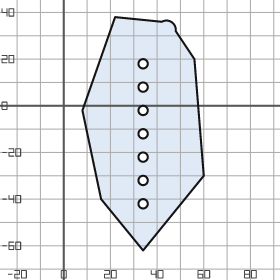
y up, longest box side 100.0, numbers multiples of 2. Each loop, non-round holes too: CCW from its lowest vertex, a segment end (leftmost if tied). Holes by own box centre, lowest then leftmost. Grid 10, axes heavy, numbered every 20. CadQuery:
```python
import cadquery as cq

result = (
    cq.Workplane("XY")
    .moveTo(34.0, -62.0)
    .lineTo(60.0, -30.0)
    .lineTo(56.0, 20.0)
    .lineTo(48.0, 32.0)
    .threePointArc((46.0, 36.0), (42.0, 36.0))
    .lineTo(22.0, 38.0)
    .lineTo(8.0, -2.0)
    .lineTo(16.0, -40.0)
    .close()
    .moveTo(34.0, -42.0)
    .circle(2.0)
    .moveTo(34.0, -32.0)
    .circle(2.0)
    .moveTo(34.0, -22.0)
    .circle(2.0)
    .moveTo(34.0, -12.0)
    .circle(2.0)
    .moveTo(34.0, -2.0)
    .circle(2.0)
    .moveTo(34.0, 8.0)
    .circle(2.0)
    .moveTo(34.0, 18.0)
    .circle(2.0)
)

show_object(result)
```